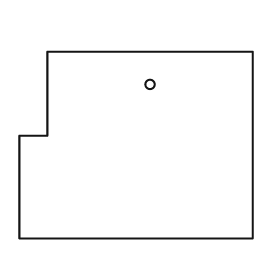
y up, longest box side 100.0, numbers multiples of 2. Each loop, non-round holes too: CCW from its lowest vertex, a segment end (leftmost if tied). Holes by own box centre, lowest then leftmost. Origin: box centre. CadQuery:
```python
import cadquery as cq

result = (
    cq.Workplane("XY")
    .moveTo(-50.0, -40.0)
    .lineTo(50.0, -40.0)
    .lineTo(50.0, 40.0)
    .lineTo(-38.0, 40.0)
    .lineTo(-38.0, 4.0)
    .lineTo(-50.0, 4.0)
    .close()
    .moveTo(6.0, 26.0)
    .circle(2.0)
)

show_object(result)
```